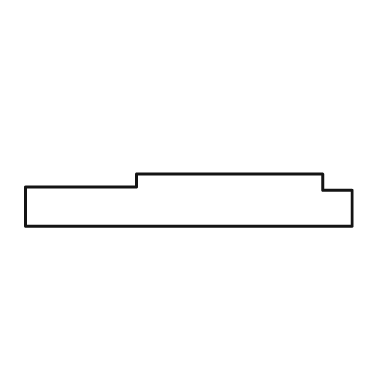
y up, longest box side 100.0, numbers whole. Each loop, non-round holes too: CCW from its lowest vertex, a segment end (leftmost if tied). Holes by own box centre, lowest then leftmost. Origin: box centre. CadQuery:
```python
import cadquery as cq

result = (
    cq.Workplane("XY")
    .moveTo(-50.0, -8.0)
    .lineTo(50.0, -8.0)
    .lineTo(50.0, 3.0)
    .lineTo(41.0, 3.0)
    .lineTo(41.0, 8.0)
    .lineTo(-16.0, 8.0)
    .lineTo(-16.0, 4.0)
    .lineTo(-50.0, 4.0)
    .close()
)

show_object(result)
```